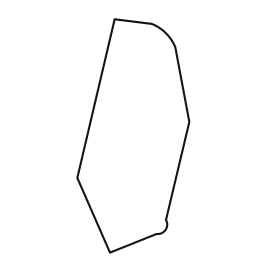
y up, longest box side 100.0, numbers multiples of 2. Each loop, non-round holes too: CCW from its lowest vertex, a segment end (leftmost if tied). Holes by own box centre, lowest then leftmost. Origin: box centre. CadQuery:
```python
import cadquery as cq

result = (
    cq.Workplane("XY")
    .moveTo(-10.0, -50.0)
    .lineTo(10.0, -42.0)
    .threePointArc((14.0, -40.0), (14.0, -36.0))
    .lineTo(24.0, 6.0)
    .lineTo(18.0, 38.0)
    .threePointArc((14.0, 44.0), (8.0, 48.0))
    .lineTo(-8.0, 50.0)
    .lineTo(-24.0, -18.0)
    .close()
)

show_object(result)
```